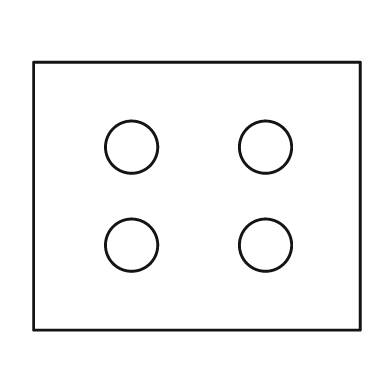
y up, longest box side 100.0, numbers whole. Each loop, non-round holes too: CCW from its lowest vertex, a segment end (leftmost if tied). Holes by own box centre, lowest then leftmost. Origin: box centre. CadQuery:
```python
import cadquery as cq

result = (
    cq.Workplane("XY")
    .moveTo(-50.0, -41.0)
    .lineTo(50.0, -41.0)
    .lineTo(50.0, 41.0)
    .lineTo(-50.0, 41.0)
    .close()
    .moveTo(-20.0, -15.0)
    .circle(8.0)
    .moveTo(21.0, -15.0)
    .circle(8.0)
    .moveTo(-20.0, 15.0)
    .circle(8.0)
    .moveTo(21.0, 15.0)
    .circle(8.0)
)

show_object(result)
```